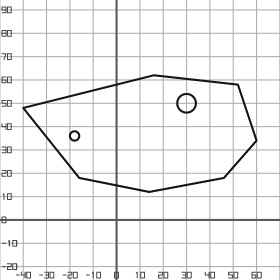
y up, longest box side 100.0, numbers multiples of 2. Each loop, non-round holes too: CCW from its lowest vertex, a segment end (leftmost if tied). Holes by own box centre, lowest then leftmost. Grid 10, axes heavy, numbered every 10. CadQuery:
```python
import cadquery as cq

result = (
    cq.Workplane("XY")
    .moveTo(14.0, 12.0)
    .lineTo(46.0, 18.0)
    .lineTo(60.0, 34.0)
    .lineTo(52.0, 58.0)
    .lineTo(16.0, 62.0)
    .lineTo(-40.0, 48.0)
    .lineTo(-16.0, 18.0)
    .close()
    .moveTo(-18.0, 36.0)
    .circle(2.0)
    .moveTo(30.0, 50.0)
    .circle(4.0)
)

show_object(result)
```